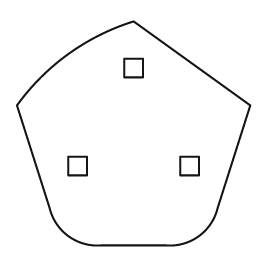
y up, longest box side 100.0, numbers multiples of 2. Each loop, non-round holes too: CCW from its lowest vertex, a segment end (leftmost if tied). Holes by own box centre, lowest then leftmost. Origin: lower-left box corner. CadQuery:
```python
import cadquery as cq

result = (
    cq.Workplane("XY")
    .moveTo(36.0, 0.0)
    .lineTo(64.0, 0.0)
    .threePointArc((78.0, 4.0), (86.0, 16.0))
    .lineTo(100.0, 60.0)
    .lineTo(50.0, 96.0)
    .threePointArc((22.0, 82.0), (0.0, 60.0))
    .lineTo(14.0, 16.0)
    .threePointArc((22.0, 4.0), (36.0, 0.0))
    .close()
    .moveTo(22.0, 30.0)
    .lineTo(30.0, 30.0)
    .lineTo(30.0, 38.0)
    .lineTo(22.0, 38.0)
    .close()
    .moveTo(70.0, 30.0)
    .lineTo(78.0, 30.0)
    .lineTo(78.0, 38.0)
    .lineTo(70.0, 38.0)
    .close()
    .moveTo(46.0, 72.0)
    .lineTo(54.0, 72.0)
    .lineTo(54.0, 80.0)
    .lineTo(46.0, 80.0)
    .close()
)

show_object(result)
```